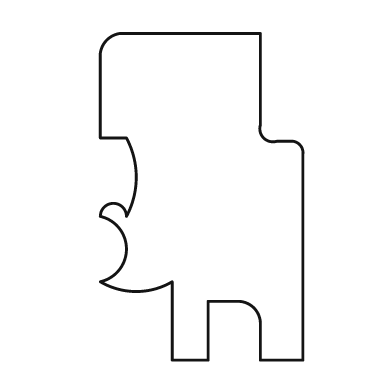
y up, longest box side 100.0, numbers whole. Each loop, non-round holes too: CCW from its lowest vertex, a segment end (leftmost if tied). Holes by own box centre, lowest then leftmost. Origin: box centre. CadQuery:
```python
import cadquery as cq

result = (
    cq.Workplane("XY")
    .moveTo(-9.0, -50.0)
    .lineTo(2.0, -50.0)
    .lineTo(2.0, -32.0)
    .lineTo(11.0, -32.0)
    .threePointArc((16.0, -34.0), (18.0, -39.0))
    .lineTo(18.0, -50.0)
    .lineTo(31.0, -50.0)
    .lineTo(31.0, 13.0)
    .threePointArc((30.0, 16.0), (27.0, 17.0))
    .lineTo(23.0, 17.0)
    .threePointArc((19.0, 18.0), (18.0, 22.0))
    .lineTo(18.0, 50.0)
    .lineTo(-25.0, 50.0)
    .threePointArc((-29.0, 48.0), (-31.0, 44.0))
    .lineTo(-31.0, 18.0)
    .lineTo(-23.0, 18.0)
    .threePointArc((-20.0, 6.0), (-23.0, -6.0))
    .threePointArc((-27.0, -2.0), (-31.0, -6.0))
    .threePointArc((-23.0, -16.0), (-31.0, -26.0))
    .threePointArc((-20.0, -29.0), (-9.0, -26.0))
    .close()
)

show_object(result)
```